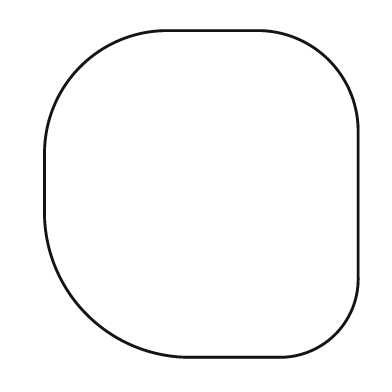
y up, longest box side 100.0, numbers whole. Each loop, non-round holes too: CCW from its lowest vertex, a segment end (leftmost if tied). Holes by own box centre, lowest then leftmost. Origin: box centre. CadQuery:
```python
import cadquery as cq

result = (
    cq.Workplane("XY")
    .moveTo(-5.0, -50.0)
    .lineTo(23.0, -50.0)
    .threePointArc((41.0, -43.0), (48.0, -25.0))
    .lineTo(48.0, 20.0)
    .threePointArc((39.0, 41.0), (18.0, 50.0))
    .lineTo(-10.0, 50.0)
    .threePointArc((-37.0, 39.0), (-48.0, 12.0))
    .lineTo(-48.0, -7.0)
    .threePointArc((-35.0, -37.0), (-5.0, -50.0))
    .close()
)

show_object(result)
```